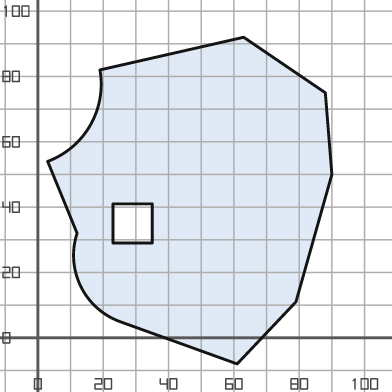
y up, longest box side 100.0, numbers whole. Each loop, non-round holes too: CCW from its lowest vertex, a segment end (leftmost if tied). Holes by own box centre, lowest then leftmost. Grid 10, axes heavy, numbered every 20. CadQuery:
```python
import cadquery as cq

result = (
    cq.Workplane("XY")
    .moveTo(61.0, -8.0)
    .lineTo(79.0, 11.0)
    .lineTo(90.0, 50.0)
    .lineTo(88.0, 75.0)
    .lineTo(63.0, 92.0)
    .lineTo(19.0, 82.0)
    .threePointArc((16.0, 65.0), (3.0, 54.0))
    .lineTo(12.0, 32.0)
    .threePointArc((13.0, 16.0), (25.0, 5.0))
    .close()
    .moveTo(23.0, 29.0)
    .lineTo(35.0, 29.0)
    .lineTo(35.0, 41.0)
    .lineTo(23.0, 41.0)
    .close()
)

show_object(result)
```